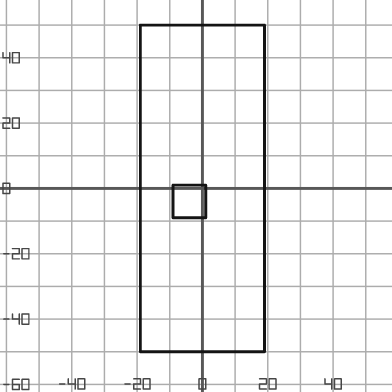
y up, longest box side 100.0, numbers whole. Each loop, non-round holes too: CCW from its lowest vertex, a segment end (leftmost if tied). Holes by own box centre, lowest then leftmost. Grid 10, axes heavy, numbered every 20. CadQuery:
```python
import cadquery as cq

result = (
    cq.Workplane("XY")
    .moveTo(-19.0, -50.0)
    .lineTo(19.0, -50.0)
    .lineTo(19.0, 50.0)
    .lineTo(-19.0, 50.0)
    .close()
    .moveTo(-9.0, -9.0)
    .lineTo(1.0, -9.0)
    .lineTo(1.0, 1.0)
    .lineTo(-9.0, 1.0)
    .close()
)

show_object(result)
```